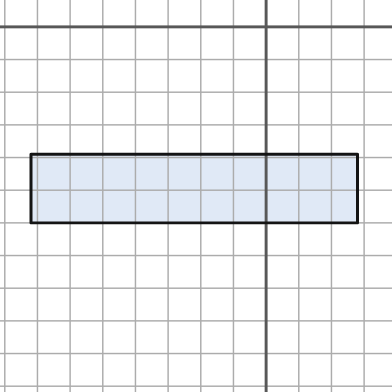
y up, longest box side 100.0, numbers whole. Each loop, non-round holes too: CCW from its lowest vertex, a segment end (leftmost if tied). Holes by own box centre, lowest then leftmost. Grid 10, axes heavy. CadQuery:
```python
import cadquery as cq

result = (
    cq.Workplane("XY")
    .moveTo(-72.0, -60.0)
    .lineTo(28.0, -60.0)
    .lineTo(28.0, -39.0)
    .lineTo(-72.0, -39.0)
    .close()
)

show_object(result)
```